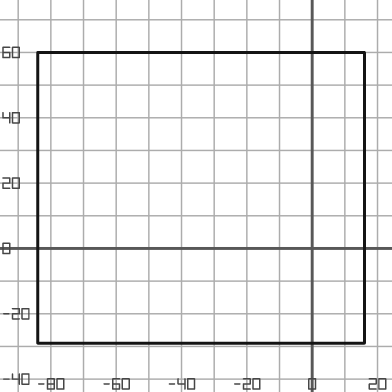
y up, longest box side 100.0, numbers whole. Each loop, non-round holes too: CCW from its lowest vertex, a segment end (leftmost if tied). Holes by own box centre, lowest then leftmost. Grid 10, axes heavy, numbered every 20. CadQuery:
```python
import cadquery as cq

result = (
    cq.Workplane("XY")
    .moveTo(-84.0, -29.0)
    .lineTo(16.0, -29.0)
    .lineTo(16.0, 60.0)
    .lineTo(-84.0, 60.0)
    .close()
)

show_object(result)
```